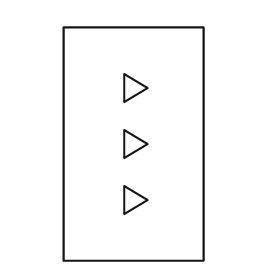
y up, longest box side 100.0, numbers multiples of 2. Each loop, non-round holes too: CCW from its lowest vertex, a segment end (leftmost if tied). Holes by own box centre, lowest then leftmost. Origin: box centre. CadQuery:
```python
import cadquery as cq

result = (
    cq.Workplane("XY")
    .moveTo(-30.0, -50.0)
    .lineTo(30.0, -50.0)
    .lineTo(30.0, 50.0)
    .lineTo(-30.0, 50.0)
    .close()
    .moveTo(-4.0, -30.0)
    .lineTo(6.0, -24.0)
    .lineTo(-4.0, -18.0)
    .close()
    .moveTo(-4.0, -6.0)
    .lineTo(6.0, 0.0)
    .lineTo(-4.0, 6.0)
    .close()
    .moveTo(-4.0, 18.0)
    .lineTo(6.0, 24.0)
    .lineTo(-4.0, 30.0)
    .close()
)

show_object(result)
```